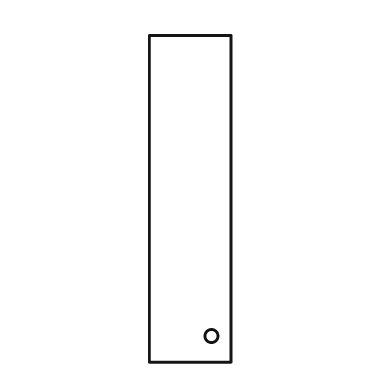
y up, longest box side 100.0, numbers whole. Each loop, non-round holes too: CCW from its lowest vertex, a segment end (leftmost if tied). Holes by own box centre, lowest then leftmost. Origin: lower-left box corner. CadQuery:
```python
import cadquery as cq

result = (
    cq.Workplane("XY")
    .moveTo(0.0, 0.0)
    .lineTo(25.0, 0.0)
    .lineTo(25.0, 100.0)
    .lineTo(0.0, 100.0)
    .close()
    .moveTo(19.0, 8.0)
    .circle(2.0)
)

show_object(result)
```